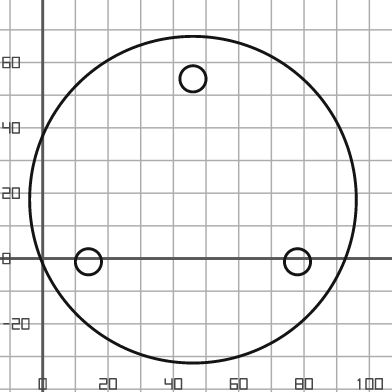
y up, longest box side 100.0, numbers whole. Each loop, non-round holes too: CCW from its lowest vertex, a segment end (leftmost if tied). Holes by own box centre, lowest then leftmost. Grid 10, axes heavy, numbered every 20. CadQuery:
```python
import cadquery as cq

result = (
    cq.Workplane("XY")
    .moveTo(46.0, 18.0)
    .circle(50.0)
    .moveTo(14.0, -1.0)
    .circle(4.0)
    .moveTo(78.0, -1.0)
    .circle(4.0)
    .moveTo(46.0, 55.0)
    .circle(4.0)
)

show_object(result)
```